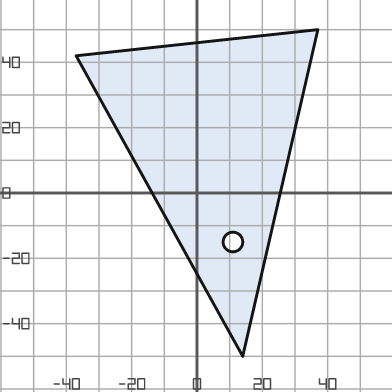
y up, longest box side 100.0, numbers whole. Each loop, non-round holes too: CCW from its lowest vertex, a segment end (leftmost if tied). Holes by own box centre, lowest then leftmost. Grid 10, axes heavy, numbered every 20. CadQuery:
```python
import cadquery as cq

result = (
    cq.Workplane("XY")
    .moveTo(14.0, -50.0)
    .lineTo(37.0, 50.0)
    .lineTo(-37.0, 42.0)
    .close()
    .moveTo(11.0, -15.0)
    .circle(3.0)
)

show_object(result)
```